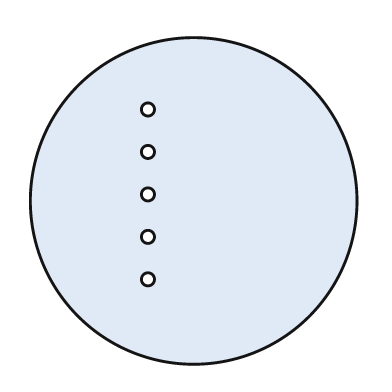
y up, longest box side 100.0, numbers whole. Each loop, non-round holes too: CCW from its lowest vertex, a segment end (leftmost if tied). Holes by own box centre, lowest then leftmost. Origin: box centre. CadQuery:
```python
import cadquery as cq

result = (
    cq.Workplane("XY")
    .moveTo(0.0, 0.0)
    .circle(50.0)
    .moveTo(-14.0, -24.0)
    .circle(2.0)
    .moveTo(-14.0, -11.0)
    .circle(2.0)
    .moveTo(-14.0, 2.0)
    .circle(2.0)
    .moveTo(-14.0, 15.0)
    .circle(2.0)
    .moveTo(-14.0, 28.0)
    .circle(2.0)
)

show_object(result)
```